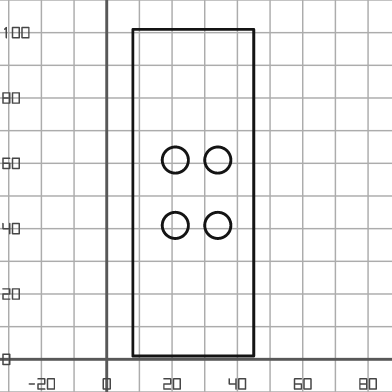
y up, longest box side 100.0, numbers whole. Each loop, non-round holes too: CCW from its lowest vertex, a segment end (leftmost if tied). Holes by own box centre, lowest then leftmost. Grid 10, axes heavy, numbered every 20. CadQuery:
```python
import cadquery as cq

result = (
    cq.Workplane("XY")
    .moveTo(8.0, 1.0)
    .lineTo(45.0, 1.0)
    .lineTo(45.0, 101.0)
    .lineTo(8.0, 101.0)
    .close()
    .moveTo(21.0, 41.0)
    .circle(4.0)
    .moveTo(34.0, 41.0)
    .circle(4.0)
    .moveTo(21.0, 61.0)
    .circle(4.0)
    .moveTo(34.0, 61.0)
    .circle(4.0)
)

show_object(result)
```